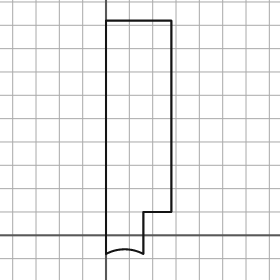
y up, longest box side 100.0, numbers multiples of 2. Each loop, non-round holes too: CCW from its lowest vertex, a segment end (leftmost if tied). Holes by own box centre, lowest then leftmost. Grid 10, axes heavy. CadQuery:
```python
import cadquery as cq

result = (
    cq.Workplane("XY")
    .moveTo(0.0, -8.0)
    .threePointArc((8.0, -6.0), (16.0, -8.0))
    .lineTo(16.0, 10.0)
    .lineTo(28.0, 10.0)
    .lineTo(28.0, 92.0)
    .lineTo(0.0, 92.0)
    .close()
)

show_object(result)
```